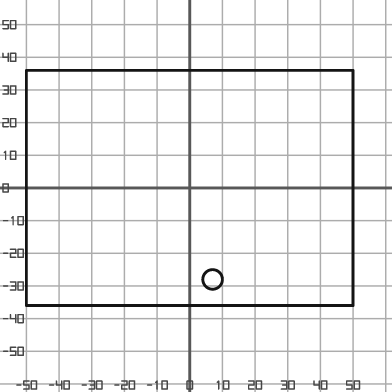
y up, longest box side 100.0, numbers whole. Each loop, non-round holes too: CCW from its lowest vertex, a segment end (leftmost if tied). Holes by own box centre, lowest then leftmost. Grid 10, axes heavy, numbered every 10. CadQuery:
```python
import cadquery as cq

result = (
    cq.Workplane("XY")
    .moveTo(-50.0, -36.0)
    .lineTo(50.0, -36.0)
    .lineTo(50.0, 36.0)
    .lineTo(-50.0, 36.0)
    .close()
    .moveTo(7.0, -28.0)
    .circle(3.0)
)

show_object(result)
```